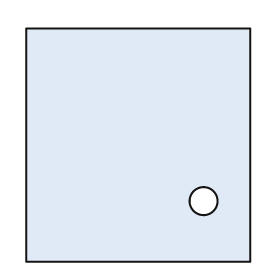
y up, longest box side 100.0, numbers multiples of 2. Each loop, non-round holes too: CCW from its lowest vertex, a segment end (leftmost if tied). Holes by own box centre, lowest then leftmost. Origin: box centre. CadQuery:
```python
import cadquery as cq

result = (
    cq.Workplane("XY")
    .moveTo(-48.0, -50.0)
    .lineTo(48.0, -50.0)
    .lineTo(48.0, 50.0)
    .lineTo(-48.0, 50.0)
    .close()
    .moveTo(28.0, -24.0)
    .circle(6.0)
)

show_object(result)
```